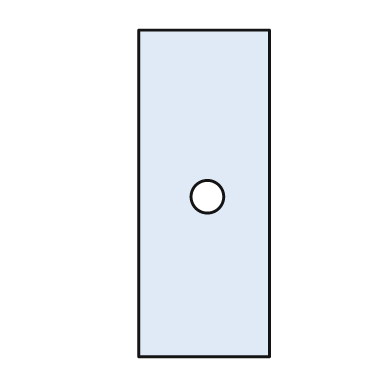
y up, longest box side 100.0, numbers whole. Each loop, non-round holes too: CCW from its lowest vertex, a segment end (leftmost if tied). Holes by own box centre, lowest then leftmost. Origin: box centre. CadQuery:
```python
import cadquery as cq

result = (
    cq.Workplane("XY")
    .moveTo(-20.0, -50.0)
    .lineTo(20.0, -50.0)
    .lineTo(20.0, 50.0)
    .lineTo(-20.0, 50.0)
    .close()
    .moveTo(1.0, -1.0)
    .circle(5.0)
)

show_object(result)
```